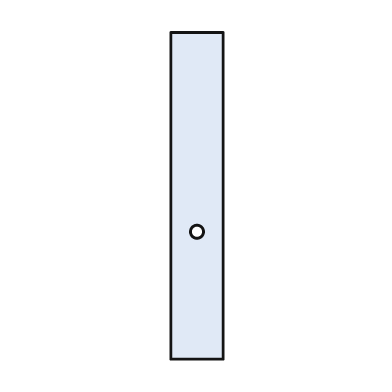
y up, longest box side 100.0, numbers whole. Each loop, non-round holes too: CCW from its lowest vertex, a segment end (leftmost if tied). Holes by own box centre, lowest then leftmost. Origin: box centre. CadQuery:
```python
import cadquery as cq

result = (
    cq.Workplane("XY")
    .moveTo(-8.0, -50.0)
    .lineTo(8.0, -50.0)
    .lineTo(8.0, 50.0)
    .lineTo(-8.0, 50.0)
    .close()
    .moveTo(0.0, -11.0)
    .circle(2.0)
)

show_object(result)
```